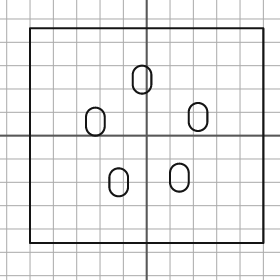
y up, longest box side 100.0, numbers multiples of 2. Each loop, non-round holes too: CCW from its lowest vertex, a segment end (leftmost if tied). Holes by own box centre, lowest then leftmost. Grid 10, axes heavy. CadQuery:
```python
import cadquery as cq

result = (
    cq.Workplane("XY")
    .moveTo(-50.0, -46.0)
    .lineTo(50.0, -46.0)
    .lineTo(50.0, 46.0)
    .lineTo(-50.0, 46.0)
    .close()
    .moveTo(-16.0, -22.0)
    .threePointArc((-12.0, -26.0), (-8.0, -22.0))
    .lineTo(-8.0, -18.0)
    .threePointArc((-12.0, -14.0), (-16.0, -18.0))
    .close()
    .moveTo(10.0, -20.0)
    .threePointArc((14.0, -24.0), (18.0, -20.0))
    .lineTo(18.0, -16.0)
    .threePointArc((14.0, -12.0), (10.0, -16.0))
    .close()
    .moveTo(-26.0, 4.0)
    .threePointArc((-22.0, 0.0), (-18.0, 4.0))
    .lineTo(-18.0, 8.0)
    .threePointArc((-22.0, 12.0), (-26.0, 8.0))
    .close()
    .moveTo(18.0, 6.0)
    .threePointArc((22.0, 2.0), (26.0, 6.0))
    .lineTo(26.0, 10.0)
    .threePointArc((22.0, 14.0), (18.0, 10.0))
    .close()
    .moveTo(-6.0, 22.0)
    .threePointArc((-2.0, 18.0), (2.0, 22.0))
    .lineTo(2.0, 26.0)
    .threePointArc((-2.0, 30.0), (-6.0, 26.0))
    .close()
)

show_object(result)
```